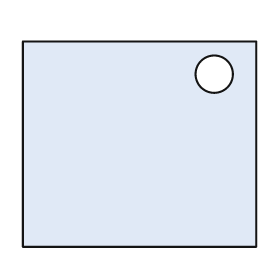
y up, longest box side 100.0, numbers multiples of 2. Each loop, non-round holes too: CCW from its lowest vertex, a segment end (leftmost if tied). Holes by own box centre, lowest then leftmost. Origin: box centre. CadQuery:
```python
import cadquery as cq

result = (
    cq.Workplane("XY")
    .moveTo(-50.0, -44.0)
    .lineTo(50.0, -44.0)
    .lineTo(50.0, 44.0)
    .lineTo(-50.0, 44.0)
    .close()
    .moveTo(32.0, 30.0)
    .circle(8.0)
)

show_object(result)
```